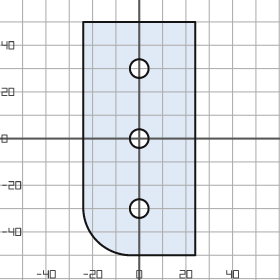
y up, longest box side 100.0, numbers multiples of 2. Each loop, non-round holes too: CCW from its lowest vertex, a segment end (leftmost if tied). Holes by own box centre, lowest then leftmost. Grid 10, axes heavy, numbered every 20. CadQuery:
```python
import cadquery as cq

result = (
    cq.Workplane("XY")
    .moveTo(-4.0, -50.0)
    .lineTo(24.0, -50.0)
    .lineTo(24.0, 50.0)
    .lineTo(-24.0, 50.0)
    .lineTo(-24.0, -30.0)
    .threePointArc((-18.0, -44.0), (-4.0, -50.0))
    .close()
    .moveTo(0.0, -30.0)
    .circle(4.0)
    .moveTo(0.0, 0.0)
    .circle(4.0)
    .moveTo(0.0, 30.0)
    .circle(4.0)
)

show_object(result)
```